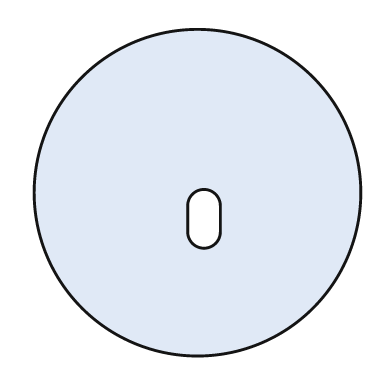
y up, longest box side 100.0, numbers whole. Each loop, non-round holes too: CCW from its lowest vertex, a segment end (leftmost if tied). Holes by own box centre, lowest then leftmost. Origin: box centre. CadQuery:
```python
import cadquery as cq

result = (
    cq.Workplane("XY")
    .moveTo(0.0, 0.0)
    .circle(50.0)
    .moveTo(-3.0, -12.0)
    .threePointArc((2.0, -17.0), (7.0, -12.0))
    .lineTo(7.0, -4.0)
    .threePointArc((2.0, 1.0), (-3.0, -4.0))
    .close()
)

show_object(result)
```